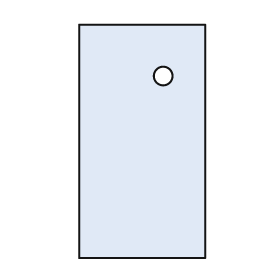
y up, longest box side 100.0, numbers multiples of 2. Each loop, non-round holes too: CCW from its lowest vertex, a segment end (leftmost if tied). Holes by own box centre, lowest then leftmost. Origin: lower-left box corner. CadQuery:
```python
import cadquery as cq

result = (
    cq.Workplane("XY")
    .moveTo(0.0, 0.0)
    .lineTo(54.0, 0.0)
    .lineTo(54.0, 100.0)
    .lineTo(0.0, 100.0)
    .close()
    .moveTo(36.0, 78.0)
    .circle(4.0)
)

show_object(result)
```